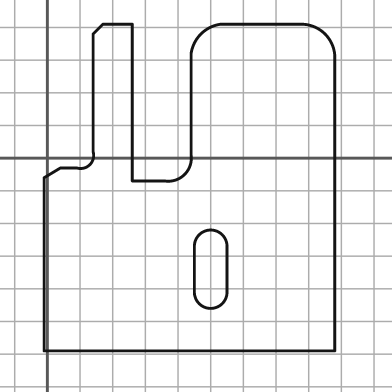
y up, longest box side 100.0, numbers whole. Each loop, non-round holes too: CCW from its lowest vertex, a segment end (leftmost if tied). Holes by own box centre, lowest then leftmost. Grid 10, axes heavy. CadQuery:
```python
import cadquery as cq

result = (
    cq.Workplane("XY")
    .moveTo(-1.0, -59.0)
    .lineTo(88.0, -59.0)
    .lineTo(88.0, 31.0)
    .threePointArc((85.0, 38.0), (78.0, 41.0))
    .lineTo(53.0, 41.0)
    .threePointArc((47.0, 38.0), (44.0, 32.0))
    .lineTo(44.0, 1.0)
    .threePointArc((42.0, -5.0), (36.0, -7.0))
    .lineTo(26.0, -7.0)
    .lineTo(26.0, 41.0)
    .lineTo(17.0, 41.0)
    .lineTo(14.0, 38.0)
    .lineTo(14.0, 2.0)
    .threePointArc((13.0, -2.0), (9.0, -3.0))
    .lineTo(4.0, -3.0)
    .lineTo(-1.0, -6.0)
    .close()
    .moveTo(45.0, -41.0)
    .threePointArc((50.0, -46.0), (55.0, -41.0))
    .lineTo(55.0, -27.0)
    .threePointArc((50.0, -22.0), (45.0, -27.0))
    .close()
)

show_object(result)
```